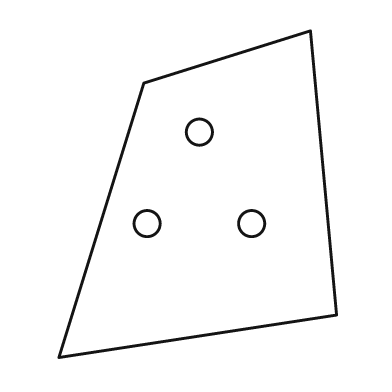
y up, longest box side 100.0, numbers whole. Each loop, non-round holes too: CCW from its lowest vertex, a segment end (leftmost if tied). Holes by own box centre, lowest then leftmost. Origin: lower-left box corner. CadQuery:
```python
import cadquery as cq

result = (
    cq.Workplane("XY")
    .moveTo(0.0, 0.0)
    .lineTo(85.0, 13.0)
    .lineTo(77.0, 100.0)
    .lineTo(26.0, 84.0)
    .close()
    .moveTo(27.0, 41.0)
    .circle(4.0)
    .moveTo(59.0, 41.0)
    .circle(4.0)
    .moveTo(43.0, 69.0)
    .circle(4.0)
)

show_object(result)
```